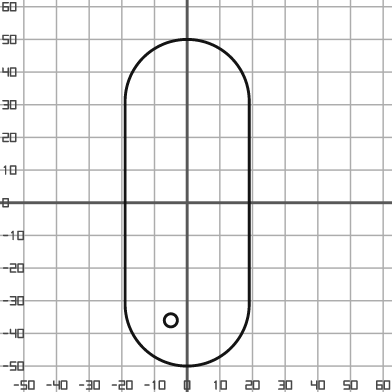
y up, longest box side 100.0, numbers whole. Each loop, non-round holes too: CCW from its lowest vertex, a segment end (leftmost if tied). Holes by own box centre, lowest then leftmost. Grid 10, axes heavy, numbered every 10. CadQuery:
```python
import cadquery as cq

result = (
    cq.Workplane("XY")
    .moveTo(-19.0, -31.0)
    .threePointArc((0.0, -50.0), (19.0, -31.0))
    .lineTo(19.0, 31.0)
    .threePointArc((0.0, 50.0), (-19.0, 31.0))
    .close()
    .moveTo(-5.0, -36.0)
    .circle(2.0)
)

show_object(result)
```